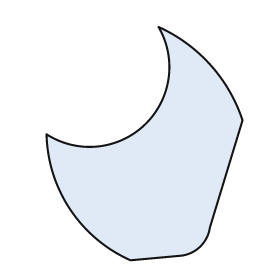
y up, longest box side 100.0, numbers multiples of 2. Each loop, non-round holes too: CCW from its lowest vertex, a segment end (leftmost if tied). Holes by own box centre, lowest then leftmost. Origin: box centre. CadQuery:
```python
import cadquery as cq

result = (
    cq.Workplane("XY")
    .moveTo(-6.0, -50.0)
    .lineTo(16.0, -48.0)
    .threePointArc((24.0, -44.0), (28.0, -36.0))
    .lineTo(42.0, 10.0)
    .threePointArc((28.0, 34.0), (6.0, 50.0))
    .threePointArc((0.0, 8.0), (-42.0, 4.0))
    .threePointArc((-32.0, -28.0), (-6.0, -50.0))
    .close()
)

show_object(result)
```